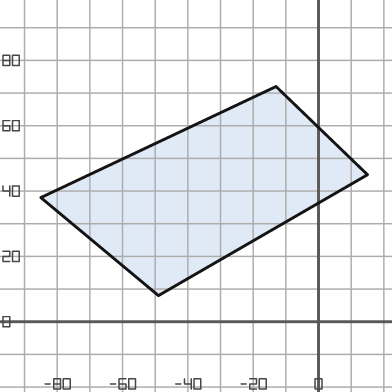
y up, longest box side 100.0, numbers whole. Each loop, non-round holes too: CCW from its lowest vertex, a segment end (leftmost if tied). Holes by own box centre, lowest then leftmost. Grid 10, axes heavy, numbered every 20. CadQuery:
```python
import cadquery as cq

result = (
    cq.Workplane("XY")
    .moveTo(-49.0, 8.0)
    .lineTo(15.0, 45.0)
    .lineTo(-13.0, 72.0)
    .lineTo(-85.0, 38.0)
    .close()
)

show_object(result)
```